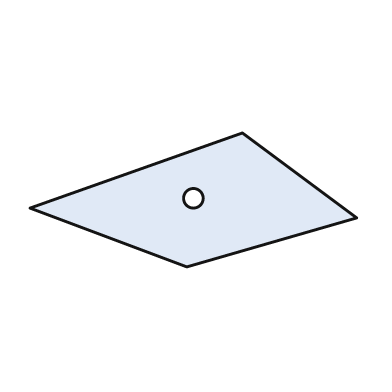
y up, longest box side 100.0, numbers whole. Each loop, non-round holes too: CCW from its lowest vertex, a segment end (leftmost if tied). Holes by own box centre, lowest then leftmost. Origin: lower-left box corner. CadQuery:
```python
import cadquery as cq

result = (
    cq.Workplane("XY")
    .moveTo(48.0, 0.0)
    .lineTo(100.0, 15.0)
    .lineTo(65.0, 41.0)
    .lineTo(0.0, 18.0)
    .close()
    .moveTo(50.0, 21.0)
    .circle(3.0)
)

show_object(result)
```